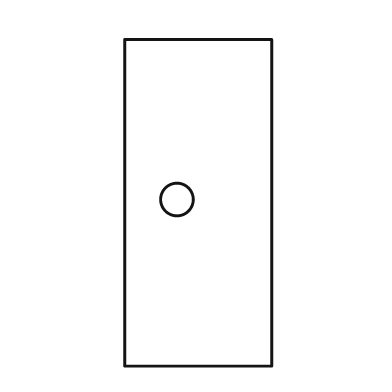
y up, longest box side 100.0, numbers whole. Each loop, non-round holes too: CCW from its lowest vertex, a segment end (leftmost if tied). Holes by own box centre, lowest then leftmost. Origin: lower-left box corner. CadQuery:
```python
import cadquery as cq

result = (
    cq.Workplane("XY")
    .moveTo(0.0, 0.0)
    .lineTo(45.0, 0.0)
    .lineTo(45.0, 100.0)
    .lineTo(0.0, 100.0)
    .close()
    .moveTo(16.0, 51.0)
    .circle(5.0)
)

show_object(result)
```